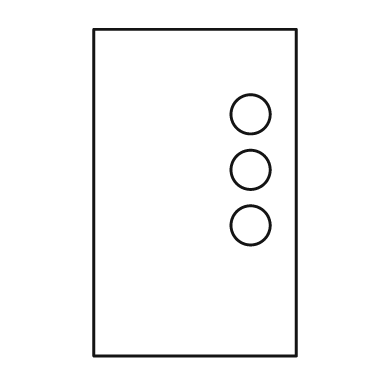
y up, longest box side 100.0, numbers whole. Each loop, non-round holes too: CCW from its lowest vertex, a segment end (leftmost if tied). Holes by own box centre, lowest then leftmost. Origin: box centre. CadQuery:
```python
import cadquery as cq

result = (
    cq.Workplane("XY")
    .moveTo(-31.0, -50.0)
    .lineTo(31.0, -50.0)
    .lineTo(31.0, 50.0)
    .lineTo(-31.0, 50.0)
    .close()
    .moveTo(17.0, -10.0)
    .circle(6.0)
    .moveTo(17.0, 7.0)
    .circle(6.0)
    .moveTo(17.0, 24.0)
    .circle(6.0)
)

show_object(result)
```